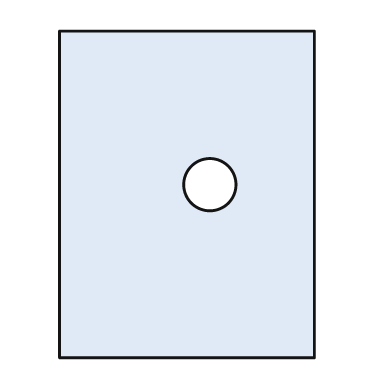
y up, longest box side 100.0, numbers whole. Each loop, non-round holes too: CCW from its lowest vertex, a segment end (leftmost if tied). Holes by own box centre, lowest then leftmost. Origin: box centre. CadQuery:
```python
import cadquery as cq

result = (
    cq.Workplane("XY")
    .moveTo(-39.0, -50.0)
    .lineTo(39.0, -50.0)
    .lineTo(39.0, 50.0)
    .lineTo(-39.0, 50.0)
    .close()
    .moveTo(7.0, 3.0)
    .circle(8.0)
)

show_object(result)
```